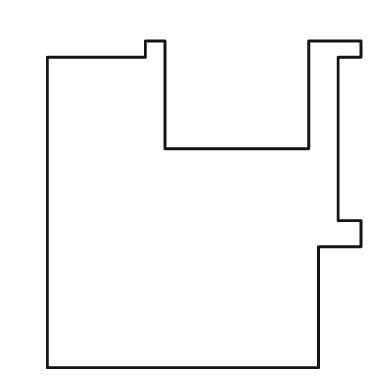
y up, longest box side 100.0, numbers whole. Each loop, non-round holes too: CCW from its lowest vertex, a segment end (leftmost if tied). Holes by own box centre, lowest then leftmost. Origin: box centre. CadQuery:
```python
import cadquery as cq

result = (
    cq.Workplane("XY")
    .moveTo(-48.0, -50.0)
    .lineTo(35.0, -50.0)
    .lineTo(35.0, -13.0)
    .lineTo(48.0, -13.0)
    .lineTo(48.0, -5.0)
    .lineTo(41.0, -5.0)
    .lineTo(41.0, 45.0)
    .lineTo(48.0, 45.0)
    .lineTo(48.0, 50.0)
    .lineTo(32.0, 50.0)
    .lineTo(32.0, 17.0)
    .lineTo(-12.0, 17.0)
    .lineTo(-12.0, 50.0)
    .lineTo(-18.0, 50.0)
    .lineTo(-18.0, 45.0)
    .lineTo(-48.0, 45.0)
    .close()
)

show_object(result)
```